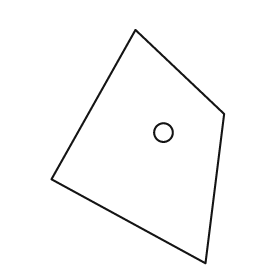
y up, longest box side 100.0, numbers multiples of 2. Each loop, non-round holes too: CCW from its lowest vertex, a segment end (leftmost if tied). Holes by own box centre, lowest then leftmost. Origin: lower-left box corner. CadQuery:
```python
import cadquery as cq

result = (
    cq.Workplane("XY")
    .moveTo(66.0, 0.0)
    .lineTo(74.0, 64.0)
    .lineTo(36.0, 100.0)
    .lineTo(0.0, 36.0)
    .close()
    .moveTo(48.0, 56.0)
    .circle(4.0)
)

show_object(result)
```